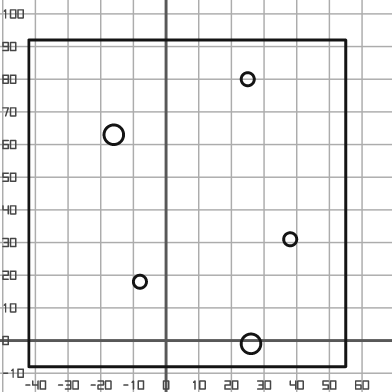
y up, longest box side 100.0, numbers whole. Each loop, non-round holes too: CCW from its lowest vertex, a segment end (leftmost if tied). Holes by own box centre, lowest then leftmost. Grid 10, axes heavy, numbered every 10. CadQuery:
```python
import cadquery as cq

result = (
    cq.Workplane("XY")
    .moveTo(-42.0, -8.0)
    .lineTo(55.0, -8.0)
    .lineTo(55.0, 92.0)
    .lineTo(-42.0, 92.0)
    .close()
    .moveTo(26.0, -1.0)
    .circle(3.0)
    .moveTo(-8.0, 18.0)
    .circle(2.0)
    .moveTo(38.0, 31.0)
    .circle(2.0)
    .moveTo(-16.0, 63.0)
    .circle(3.0)
    .moveTo(25.0, 80.0)
    .circle(2.0)
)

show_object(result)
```